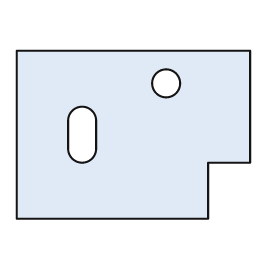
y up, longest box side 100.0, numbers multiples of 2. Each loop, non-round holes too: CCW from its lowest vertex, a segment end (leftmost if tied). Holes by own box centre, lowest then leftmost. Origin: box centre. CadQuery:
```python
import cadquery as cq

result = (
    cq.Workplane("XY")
    .moveTo(-50.0, -36.0)
    .lineTo(32.0, -36.0)
    .lineTo(32.0, -12.0)
    .lineTo(50.0, -12.0)
    .lineTo(50.0, 36.0)
    .lineTo(-50.0, 36.0)
    .close()
    .moveTo(-28.0, -6.0)
    .threePointArc((-22.0, -12.0), (-16.0, -6.0))
    .lineTo(-16.0, 6.0)
    .threePointArc((-22.0, 12.0), (-28.0, 6.0))
    .close()
    .moveTo(14.0, 22.0)
    .circle(6.0)
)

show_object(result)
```